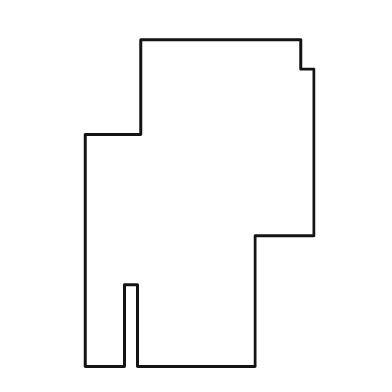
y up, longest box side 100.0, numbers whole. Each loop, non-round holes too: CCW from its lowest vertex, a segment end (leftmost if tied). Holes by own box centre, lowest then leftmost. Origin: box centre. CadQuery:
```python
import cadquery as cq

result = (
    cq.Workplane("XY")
    .moveTo(-35.0, -50.0)
    .lineTo(-23.0, -50.0)
    .lineTo(-23.0, -25.0)
    .lineTo(-19.0, -25.0)
    .lineTo(-19.0, -50.0)
    .lineTo(17.0, -50.0)
    .lineTo(17.0, -10.0)
    .lineTo(35.0, -10.0)
    .lineTo(35.0, 41.0)
    .lineTo(31.0, 41.0)
    .lineTo(31.0, 50.0)
    .lineTo(-18.0, 50.0)
    .lineTo(-18.0, 21.0)
    .lineTo(-35.0, 21.0)
    .close()
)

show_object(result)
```